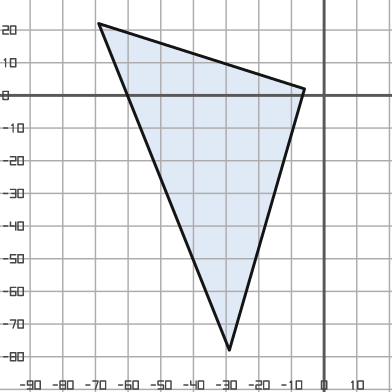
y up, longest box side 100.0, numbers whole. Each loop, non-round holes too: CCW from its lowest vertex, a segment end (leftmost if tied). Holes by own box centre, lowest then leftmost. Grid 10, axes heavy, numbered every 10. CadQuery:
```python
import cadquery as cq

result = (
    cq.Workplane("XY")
    .moveTo(-29.0, -78.0)
    .lineTo(-6.0, 2.0)
    .lineTo(-69.0, 22.0)
    .close()
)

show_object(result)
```